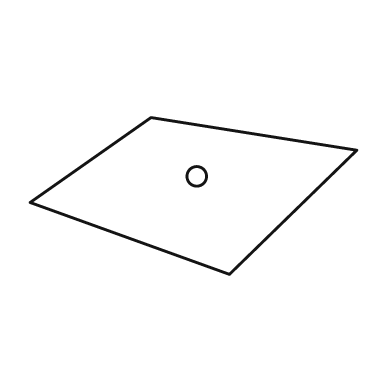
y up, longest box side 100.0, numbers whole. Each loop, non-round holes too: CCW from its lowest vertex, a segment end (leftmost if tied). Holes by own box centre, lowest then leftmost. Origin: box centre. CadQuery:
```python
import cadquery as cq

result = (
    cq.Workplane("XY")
    .moveTo(11.0, -24.0)
    .lineTo(50.0, 14.0)
    .lineTo(-13.0, 24.0)
    .lineTo(-50.0, -2.0)
    .close()
    .moveTo(1.0, 6.0)
    .circle(3.0)
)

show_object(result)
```